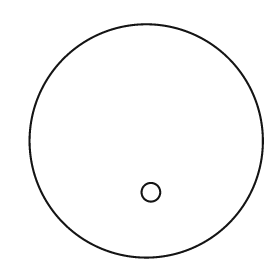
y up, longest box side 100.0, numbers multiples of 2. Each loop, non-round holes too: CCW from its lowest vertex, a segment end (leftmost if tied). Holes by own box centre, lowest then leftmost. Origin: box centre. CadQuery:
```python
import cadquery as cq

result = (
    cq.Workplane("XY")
    .moveTo(0.0, 0.0)
    .circle(50.0)
    .moveTo(2.0, -22.0)
    .circle(4.0)
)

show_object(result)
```